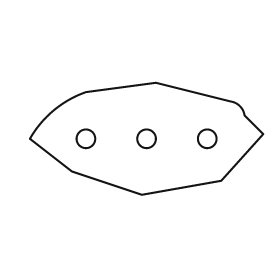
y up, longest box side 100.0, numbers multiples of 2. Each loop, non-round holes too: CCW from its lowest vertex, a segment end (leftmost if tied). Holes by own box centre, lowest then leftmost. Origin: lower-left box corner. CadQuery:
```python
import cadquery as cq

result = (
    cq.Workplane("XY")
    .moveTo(48.0, 0.0)
    .lineTo(82.0, 6.0)
    .lineTo(100.0, 26.0)
    .lineTo(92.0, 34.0)
    .threePointArc((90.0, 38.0), (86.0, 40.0))
    .lineTo(54.0, 48.0)
    .lineTo(24.0, 44.0)
    .threePointArc((10.0, 36.0), (0.0, 24.0))
    .lineTo(18.0, 10.0)
    .close()
    .moveTo(24.0, 24.0)
    .circle(4.0)
    .moveTo(50.0, 24.0)
    .circle(4.0)
    .moveTo(76.0, 24.0)
    .circle(4.0)
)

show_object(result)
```